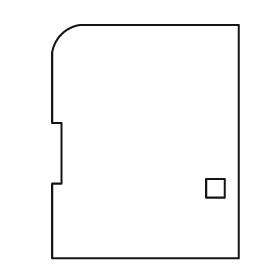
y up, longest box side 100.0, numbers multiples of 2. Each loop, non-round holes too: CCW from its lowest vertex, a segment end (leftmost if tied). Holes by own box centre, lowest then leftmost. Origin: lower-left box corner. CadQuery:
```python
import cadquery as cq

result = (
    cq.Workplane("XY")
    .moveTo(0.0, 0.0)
    .lineTo(80.0, 0.0)
    .lineTo(80.0, 100.0)
    .lineTo(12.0, 100.0)
    .threePointArc((4.0, 96.0), (0.0, 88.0))
    .lineTo(0.0, 58.0)
    .lineTo(4.0, 58.0)
    .lineTo(4.0, 32.0)
    .lineTo(0.0, 32.0)
    .close()
    .moveTo(66.0, 26.0)
    .lineTo(74.0, 26.0)
    .lineTo(74.0, 34.0)
    .lineTo(66.0, 34.0)
    .close()
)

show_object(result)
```